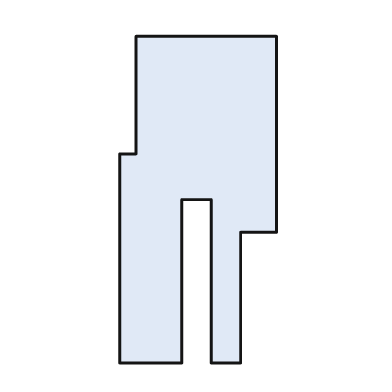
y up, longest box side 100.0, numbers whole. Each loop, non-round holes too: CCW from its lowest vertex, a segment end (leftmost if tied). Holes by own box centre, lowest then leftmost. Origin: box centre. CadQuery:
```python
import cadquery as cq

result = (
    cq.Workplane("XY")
    .moveTo(-24.0, -50.0)
    .lineTo(-5.0, -50.0)
    .lineTo(-5.0, 0.0)
    .lineTo(4.0, 0.0)
    .lineTo(4.0, -50.0)
    .lineTo(13.0, -50.0)
    .lineTo(13.0, -10.0)
    .lineTo(24.0, -10.0)
    .lineTo(24.0, 50.0)
    .lineTo(-19.0, 50.0)
    .lineTo(-19.0, 14.0)
    .lineTo(-24.0, 14.0)
    .close()
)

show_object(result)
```